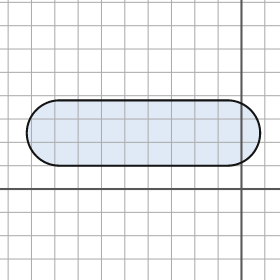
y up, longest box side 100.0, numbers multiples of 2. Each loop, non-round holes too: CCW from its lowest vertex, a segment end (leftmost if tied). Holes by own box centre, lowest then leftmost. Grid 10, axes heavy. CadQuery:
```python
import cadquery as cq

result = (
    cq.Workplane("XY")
    .moveTo(-78.0, 10.0)
    .lineTo(-6.0, 10.0)
    .threePointArc((8.0, 24.0), (-6.0, 38.0))
    .lineTo(-78.0, 38.0)
    .threePointArc((-92.0, 24.0), (-78.0, 10.0))
    .close()
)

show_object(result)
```